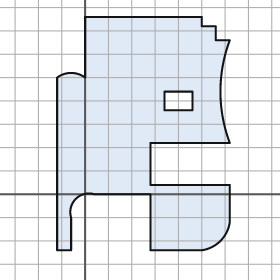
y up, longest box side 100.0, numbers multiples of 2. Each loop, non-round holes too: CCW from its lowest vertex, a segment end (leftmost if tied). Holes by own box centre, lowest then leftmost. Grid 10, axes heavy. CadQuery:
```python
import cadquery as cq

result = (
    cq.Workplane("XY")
    .moveTo(-12.0, -24.0)
    .lineTo(-6.0, -24.0)
    .lineTo(-6.0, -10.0)
    .threePointArc((-4.0, -2.0), (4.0, 0.0))
    .lineTo(28.0, 0.0)
    .lineTo(28.0, -24.0)
    .lineTo(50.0, -24.0)
    .threePointArc((58.0, -20.0), (62.0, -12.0))
    .lineTo(62.0, 4.0)
    .lineTo(28.0, 4.0)
    .lineTo(28.0, 22.0)
    .lineTo(62.0, 22.0)
    .threePointArc((58.0, 44.0), (62.0, 66.0))
    .lineTo(56.0, 66.0)
    .lineTo(56.0, 72.0)
    .lineTo(50.0, 72.0)
    .lineTo(50.0, 76.0)
    .lineTo(0.0, 76.0)
    .lineTo(0.0, 50.0)
    .threePointArc((-6.0, 52.0), (-12.0, 50.0))
    .close()
    .moveTo(34.0, 36.0)
    .lineTo(46.0, 36.0)
    .lineTo(46.0, 44.0)
    .lineTo(34.0, 44.0)
    .close()
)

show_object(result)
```